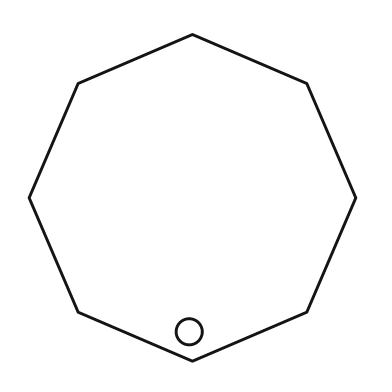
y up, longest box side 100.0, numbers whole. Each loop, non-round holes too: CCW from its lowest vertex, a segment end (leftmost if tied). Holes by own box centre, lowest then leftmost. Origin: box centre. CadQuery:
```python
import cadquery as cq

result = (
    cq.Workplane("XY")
    .moveTo(0.0, -50.0)
    .lineTo(35.0, -35.0)
    .lineTo(50.0, 0.0)
    .lineTo(35.0, 35.0)
    .lineTo(0.0, 50.0)
    .lineTo(-35.0, 35.0)
    .lineTo(-50.0, 0.0)
    .lineTo(-35.0, -35.0)
    .close()
    .moveTo(-1.0, -41.0)
    .circle(4.0)
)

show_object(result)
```